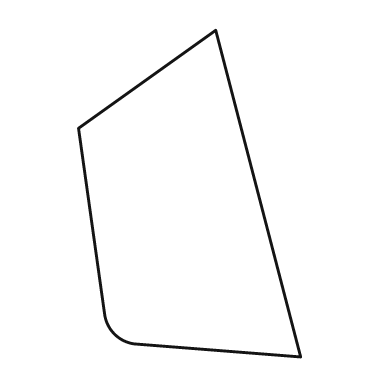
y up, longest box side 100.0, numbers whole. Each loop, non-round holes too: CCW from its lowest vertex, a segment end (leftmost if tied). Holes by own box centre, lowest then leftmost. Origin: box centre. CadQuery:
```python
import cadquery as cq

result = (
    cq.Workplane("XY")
    .moveTo(34.0, -50.0)
    .lineTo(8.0, 50.0)
    .lineTo(-34.0, 20.0)
    .lineTo(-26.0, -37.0)
    .threePointArc((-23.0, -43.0), (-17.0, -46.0))
    .close()
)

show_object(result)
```